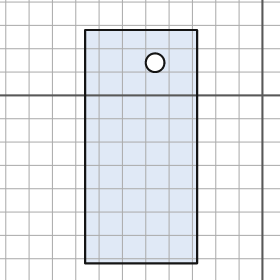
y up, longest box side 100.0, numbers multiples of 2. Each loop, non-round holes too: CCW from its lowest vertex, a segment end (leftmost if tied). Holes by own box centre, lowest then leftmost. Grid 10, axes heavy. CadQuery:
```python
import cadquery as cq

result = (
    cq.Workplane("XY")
    .moveTo(-76.0, -72.0)
    .lineTo(-28.0, -72.0)
    .lineTo(-28.0, 28.0)
    .lineTo(-76.0, 28.0)
    .close()
    .moveTo(-46.0, 14.0)
    .circle(4.0)
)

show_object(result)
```